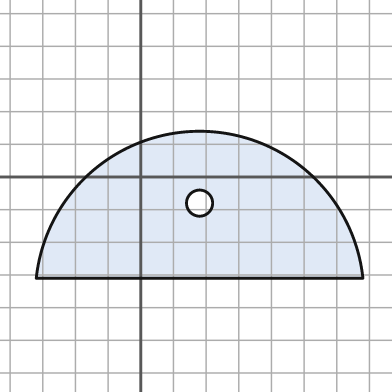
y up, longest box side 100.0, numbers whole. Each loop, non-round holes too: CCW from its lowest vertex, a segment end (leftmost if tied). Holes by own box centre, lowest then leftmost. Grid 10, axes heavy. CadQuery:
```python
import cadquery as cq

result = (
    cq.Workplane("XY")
    .moveTo(-32.0, -31.0)
    .lineTo(68.0, -31.0)
    .threePointArc((18.0, 14.0), (-32.0, -31.0))
    .close()
    .moveTo(18.0, -8.0)
    .circle(4.0)
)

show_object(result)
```